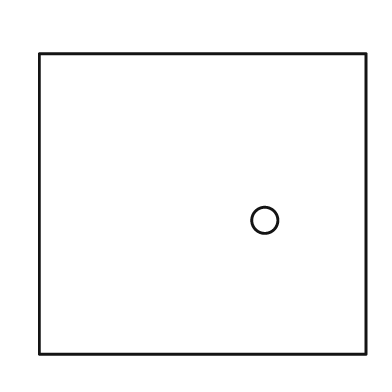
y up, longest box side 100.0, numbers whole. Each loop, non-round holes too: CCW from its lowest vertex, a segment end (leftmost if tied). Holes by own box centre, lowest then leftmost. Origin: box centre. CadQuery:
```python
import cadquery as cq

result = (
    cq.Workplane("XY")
    .moveTo(-50.0, -46.0)
    .lineTo(50.0, -46.0)
    .lineTo(50.0, 46.0)
    .lineTo(-50.0, 46.0)
    .close()
    .moveTo(19.0, -5.0)
    .circle(4.0)
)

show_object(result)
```